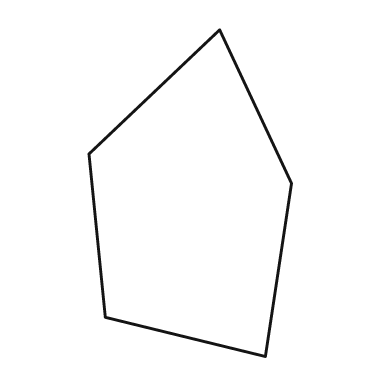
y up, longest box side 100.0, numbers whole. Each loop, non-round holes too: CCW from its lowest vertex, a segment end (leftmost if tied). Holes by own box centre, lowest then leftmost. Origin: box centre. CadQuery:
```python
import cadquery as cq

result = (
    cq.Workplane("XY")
    .moveTo(23.0, -50.0)
    .lineTo(31.0, 3.0)
    .lineTo(9.0, 50.0)
    .lineTo(-31.0, 12.0)
    .lineTo(-26.0, -38.0)
    .close()
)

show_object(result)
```